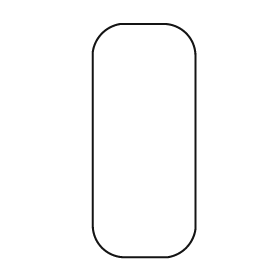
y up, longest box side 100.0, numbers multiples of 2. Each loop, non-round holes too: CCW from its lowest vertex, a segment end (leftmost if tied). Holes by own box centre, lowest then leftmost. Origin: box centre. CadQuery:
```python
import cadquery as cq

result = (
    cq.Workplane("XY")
    .moveTo(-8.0, -50.0)
    .lineTo(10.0, -50.0)
    .threePointArc((18.0, -46.0), (22.0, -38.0))
    .lineTo(22.0, 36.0)
    .threePointArc((18.0, 46.0), (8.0, 50.0))
    .lineTo(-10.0, 50.0)
    .threePointArc((-18.0, 46.0), (-22.0, 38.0))
    .lineTo(-22.0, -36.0)
    .threePointArc((-18.0, -46.0), (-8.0, -50.0))
    .close()
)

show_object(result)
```